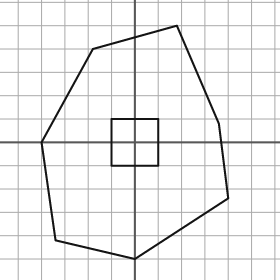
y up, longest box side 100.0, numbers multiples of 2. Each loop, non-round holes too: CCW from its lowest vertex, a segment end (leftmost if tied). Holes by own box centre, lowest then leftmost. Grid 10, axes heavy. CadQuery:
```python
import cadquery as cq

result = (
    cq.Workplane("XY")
    .moveTo(0.0, -50.0)
    .lineTo(40.0, -24.0)
    .lineTo(36.0, 8.0)
    .lineTo(18.0, 50.0)
    .lineTo(-18.0, 40.0)
    .lineTo(-40.0, 0.0)
    .lineTo(-34.0, -42.0)
    .close()
    .moveTo(-10.0, -10.0)
    .lineTo(10.0, -10.0)
    .lineTo(10.0, 10.0)
    .lineTo(-10.0, 10.0)
    .close()
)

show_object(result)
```